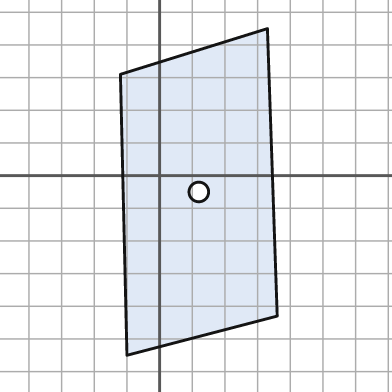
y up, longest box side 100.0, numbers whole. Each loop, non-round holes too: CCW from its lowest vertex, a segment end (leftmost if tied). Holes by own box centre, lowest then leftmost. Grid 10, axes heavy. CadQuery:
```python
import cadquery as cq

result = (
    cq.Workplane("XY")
    .moveTo(-10.0, -55.0)
    .lineTo(36.0, -43.0)
    .lineTo(33.0, 45.0)
    .lineTo(-12.0, 31.0)
    .close()
    .moveTo(12.0, -5.0)
    .circle(3.0)
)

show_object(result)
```